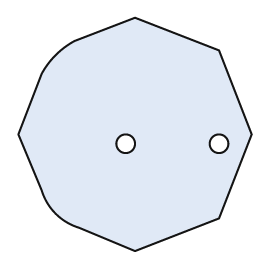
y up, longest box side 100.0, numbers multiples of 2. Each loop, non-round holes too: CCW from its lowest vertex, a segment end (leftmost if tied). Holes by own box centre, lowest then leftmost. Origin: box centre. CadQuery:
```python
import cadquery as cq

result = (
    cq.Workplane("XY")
    .moveTo(0.0, -50.0)
    .lineTo(36.0, -36.0)
    .lineTo(50.0, 0.0)
    .lineTo(36.0, 36.0)
    .lineTo(0.0, 50.0)
    .lineTo(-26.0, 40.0)
    .threePointArc((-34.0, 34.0), (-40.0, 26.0))
    .lineTo(-50.0, 0.0)
    .lineTo(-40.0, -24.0)
    .threePointArc((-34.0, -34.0), (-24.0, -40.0))
    .close()
    .moveTo(-4.0, -4.0)
    .circle(4.0)
    .moveTo(36.0, -4.0)
    .circle(4.0)
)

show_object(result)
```